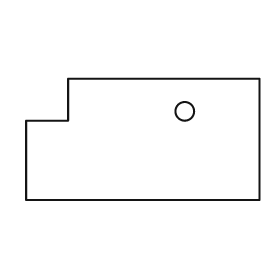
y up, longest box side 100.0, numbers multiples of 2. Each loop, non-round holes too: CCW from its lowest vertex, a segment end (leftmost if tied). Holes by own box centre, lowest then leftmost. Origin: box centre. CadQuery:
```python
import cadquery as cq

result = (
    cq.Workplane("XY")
    .moveTo(-50.0, -26.0)
    .lineTo(50.0, -26.0)
    .lineTo(50.0, 26.0)
    .lineTo(-32.0, 26.0)
    .lineTo(-32.0, 8.0)
    .lineTo(-50.0, 8.0)
    .close()
    .moveTo(18.0, 12.0)
    .circle(4.0)
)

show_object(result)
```